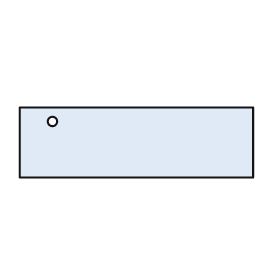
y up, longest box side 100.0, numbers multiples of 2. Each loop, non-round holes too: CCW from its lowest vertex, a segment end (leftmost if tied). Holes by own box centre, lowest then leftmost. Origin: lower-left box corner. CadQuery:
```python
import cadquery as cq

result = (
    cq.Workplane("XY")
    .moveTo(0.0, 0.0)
    .lineTo(100.0, 0.0)
    .lineTo(100.0, 30.0)
    .lineTo(0.0, 30.0)
    .close()
    .moveTo(14.0, 24.0)
    .circle(2.0)
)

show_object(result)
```